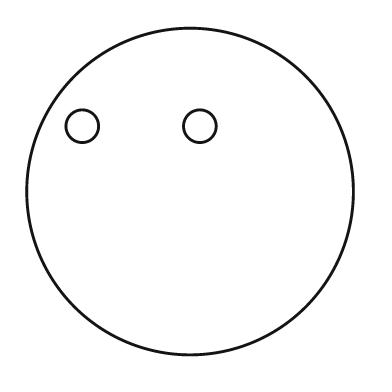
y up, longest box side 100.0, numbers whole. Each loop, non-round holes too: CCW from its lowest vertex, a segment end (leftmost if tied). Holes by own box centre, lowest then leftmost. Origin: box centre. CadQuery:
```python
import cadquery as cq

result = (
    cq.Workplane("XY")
    .moveTo(0.0, 0.0)
    .circle(50.0)
    .moveTo(-33.0, 20.0)
    .circle(5.0)
    .moveTo(3.0, 20.0)
    .circle(5.0)
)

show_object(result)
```